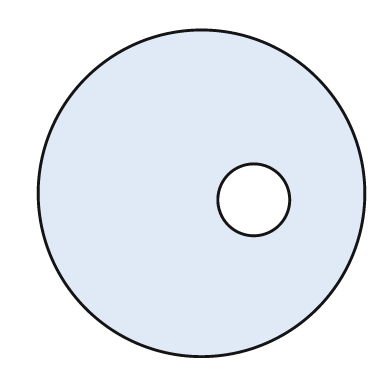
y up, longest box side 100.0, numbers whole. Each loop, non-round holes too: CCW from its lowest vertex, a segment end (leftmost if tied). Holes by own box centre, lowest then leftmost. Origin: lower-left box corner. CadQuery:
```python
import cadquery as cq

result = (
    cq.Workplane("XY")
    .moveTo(50.0, 50.0)
    .circle(50.0)
    .moveTo(66.0, 48.0)
    .circle(11.0)
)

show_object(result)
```